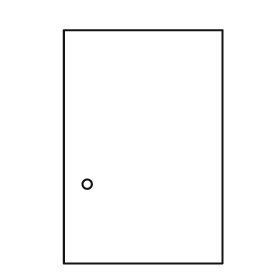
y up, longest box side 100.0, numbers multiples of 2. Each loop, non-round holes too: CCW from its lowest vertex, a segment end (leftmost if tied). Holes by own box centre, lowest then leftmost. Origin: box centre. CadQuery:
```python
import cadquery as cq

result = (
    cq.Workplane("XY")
    .moveTo(-34.0, -50.0)
    .lineTo(34.0, -50.0)
    .lineTo(34.0, 50.0)
    .lineTo(-34.0, 50.0)
    .close()
    .moveTo(-24.0, -16.0)
    .circle(2.0)
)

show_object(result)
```